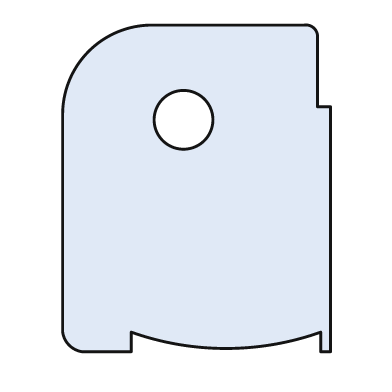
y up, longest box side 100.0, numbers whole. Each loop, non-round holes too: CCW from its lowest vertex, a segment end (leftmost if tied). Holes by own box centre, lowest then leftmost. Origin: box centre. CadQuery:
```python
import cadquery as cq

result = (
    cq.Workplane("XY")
    .moveTo(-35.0, -50.0)
    .lineTo(-20.0, -50.0)
    .lineTo(-20.0, -44.0)
    .threePointArc((9.0, -49.0), (38.0, -44.0))
    .lineTo(38.0, -50.0)
    .lineTo(41.0, -50.0)
    .lineTo(41.0, 25.0)
    .lineTo(37.0, 25.0)
    .lineTo(37.0, 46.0)
    .threePointArc((36.0, 49.0), (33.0, 50.0))
    .lineTo(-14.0, 50.0)
    .threePointArc((-33.0, 42.0), (-41.0, 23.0))
    .lineTo(-41.0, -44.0)
    .threePointArc((-39.0, -48.0), (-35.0, -50.0))
    .close()
    .moveTo(-4.0, 21.0)
    .circle(9.0)
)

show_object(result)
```